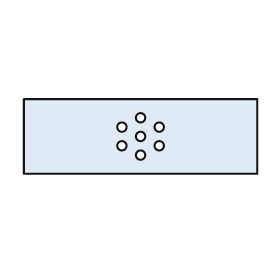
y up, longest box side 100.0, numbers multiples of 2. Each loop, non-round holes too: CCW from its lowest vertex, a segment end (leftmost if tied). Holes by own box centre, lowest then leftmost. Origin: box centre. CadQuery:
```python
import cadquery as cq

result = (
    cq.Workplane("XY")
    .moveTo(-50.0, -16.0)
    .lineTo(50.0, -16.0)
    .lineTo(50.0, 16.0)
    .lineTo(-50.0, 16.0)
    .close()
    .moveTo(0.0, -8.0)
    .circle(2.0)
    .moveTo(-8.0, -4.0)
    .circle(2.0)
    .moveTo(8.0, -4.0)
    .circle(2.0)
    .moveTo(0.0, 0.0)
    .circle(2.0)
    .moveTo(-8.0, 4.0)
    .circle(2.0)
    .moveTo(8.0, 4.0)
    .circle(2.0)
    .moveTo(0.0, 8.0)
    .circle(2.0)
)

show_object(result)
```